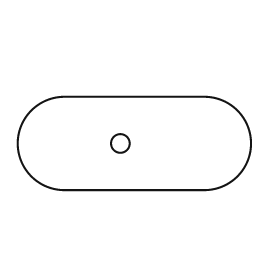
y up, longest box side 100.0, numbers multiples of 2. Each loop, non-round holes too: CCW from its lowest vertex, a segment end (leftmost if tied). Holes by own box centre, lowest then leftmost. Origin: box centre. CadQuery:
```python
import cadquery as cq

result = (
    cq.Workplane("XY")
    .moveTo(-30.0, -20.0)
    .lineTo(30.0, -20.0)
    .threePointArc((50.0, 0.0), (30.0, 20.0))
    .lineTo(-30.0, 20.0)
    .threePointArc((-50.0, 0.0), (-30.0, -20.0))
    .close()
    .moveTo(-6.0, 0.0)
    .circle(4.0)
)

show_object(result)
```